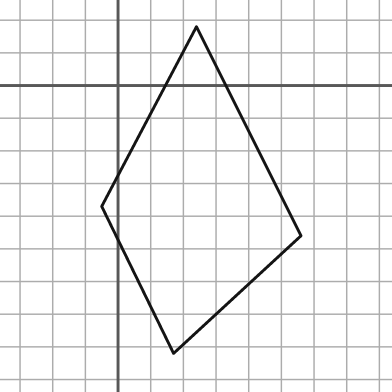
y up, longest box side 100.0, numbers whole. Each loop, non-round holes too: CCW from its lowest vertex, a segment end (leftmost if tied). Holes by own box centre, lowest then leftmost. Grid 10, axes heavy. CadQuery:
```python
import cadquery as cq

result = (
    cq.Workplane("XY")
    .moveTo(17.0, -82.0)
    .lineTo(56.0, -46.0)
    .lineTo(24.0, 18.0)
    .lineTo(-5.0, -37.0)
    .close()
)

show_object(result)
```